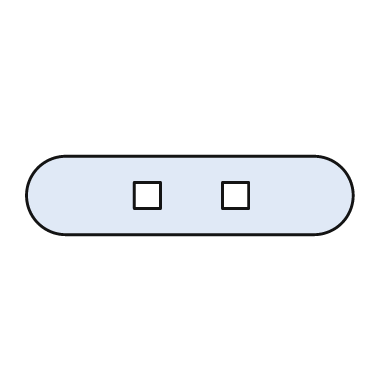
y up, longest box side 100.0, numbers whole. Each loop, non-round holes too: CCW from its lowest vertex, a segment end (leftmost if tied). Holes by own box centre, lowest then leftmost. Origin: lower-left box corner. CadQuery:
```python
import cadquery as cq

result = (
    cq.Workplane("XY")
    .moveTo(12.0, 0.0)
    .lineTo(88.0, 0.0)
    .threePointArc((100.0, 12.0), (88.0, 24.0))
    .lineTo(12.0, 24.0)
    .threePointArc((0.0, 12.0), (12.0, 0.0))
    .close()
    .moveTo(33.0, 8.0)
    .lineTo(41.0, 8.0)
    .lineTo(41.0, 16.0)
    .lineTo(33.0, 16.0)
    .close()
    .moveTo(60.0, 8.0)
    .lineTo(68.0, 8.0)
    .lineTo(68.0, 16.0)
    .lineTo(60.0, 16.0)
    .close()
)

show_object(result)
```